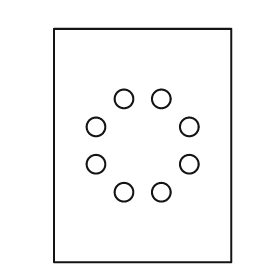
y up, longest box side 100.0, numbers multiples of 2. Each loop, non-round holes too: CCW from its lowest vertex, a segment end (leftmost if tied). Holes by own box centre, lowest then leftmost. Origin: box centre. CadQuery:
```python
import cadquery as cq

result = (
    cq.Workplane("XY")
    .moveTo(-38.0, -50.0)
    .lineTo(38.0, -50.0)
    .lineTo(38.0, 50.0)
    .lineTo(-38.0, 50.0)
    .close()
    .moveTo(-8.0, -20.0)
    .circle(4.0)
    .moveTo(8.0, -20.0)
    .circle(4.0)
    .moveTo(-20.0, -8.0)
    .circle(4.0)
    .moveTo(20.0, -8.0)
    .circle(4.0)
    .moveTo(-20.0, 8.0)
    .circle(4.0)
    .moveTo(20.0, 8.0)
    .circle(4.0)
    .moveTo(-8.0, 20.0)
    .circle(4.0)
    .moveTo(8.0, 20.0)
    .circle(4.0)
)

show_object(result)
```